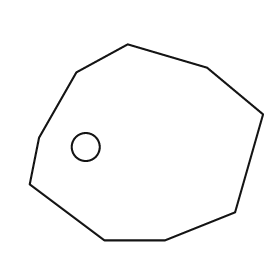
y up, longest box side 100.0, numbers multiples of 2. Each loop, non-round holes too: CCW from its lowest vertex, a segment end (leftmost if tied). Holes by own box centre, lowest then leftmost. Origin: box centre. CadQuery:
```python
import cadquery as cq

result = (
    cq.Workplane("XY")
    .moveTo(-18.0, -42.0)
    .lineTo(8.0, -42.0)
    .lineTo(38.0, -30.0)
    .lineTo(50.0, 12.0)
    .lineTo(26.0, 32.0)
    .lineTo(-8.0, 42.0)
    .lineTo(-30.0, 30.0)
    .lineTo(-46.0, 2.0)
    .lineTo(-50.0, -18.0)
    .close()
    .moveTo(-26.0, -2.0)
    .circle(6.0)
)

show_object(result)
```